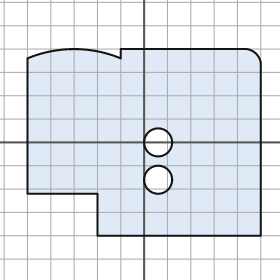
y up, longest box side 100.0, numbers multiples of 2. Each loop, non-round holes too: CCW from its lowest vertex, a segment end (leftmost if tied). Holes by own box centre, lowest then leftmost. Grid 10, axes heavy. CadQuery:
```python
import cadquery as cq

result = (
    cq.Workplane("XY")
    .moveTo(-20.0, -40.0)
    .lineTo(50.0, -40.0)
    .lineTo(50.0, 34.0)
    .threePointArc((48.0, 38.0), (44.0, 40.0))
    .lineTo(-10.0, 40.0)
    .lineTo(-10.0, 36.0)
    .threePointArc((-30.0, 40.0), (-50.0, 36.0))
    .lineTo(-50.0, -22.0)
    .lineTo(-20.0, -22.0)
    .close()
    .moveTo(6.0, -16.0)
    .circle(6.0)
    .moveTo(6.0, 0.0)
    .circle(6.0)
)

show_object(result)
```